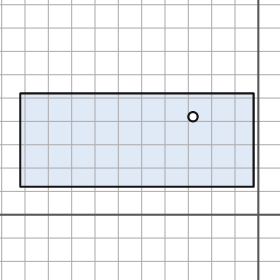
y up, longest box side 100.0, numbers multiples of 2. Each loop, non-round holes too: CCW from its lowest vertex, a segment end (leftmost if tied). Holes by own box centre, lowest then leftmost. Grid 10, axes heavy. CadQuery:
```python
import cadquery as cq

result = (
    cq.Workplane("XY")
    .moveTo(-102.0, 12.0)
    .lineTo(-2.0, 12.0)
    .lineTo(-2.0, 52.0)
    .lineTo(-102.0, 52.0)
    .close()
    .moveTo(-28.0, 42.0)
    .circle(2.0)
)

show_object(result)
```